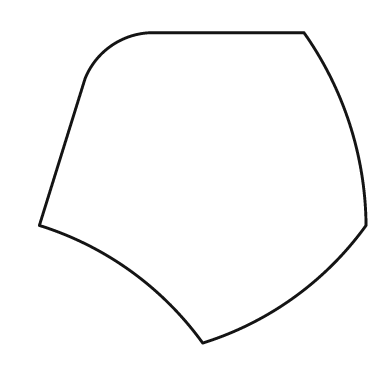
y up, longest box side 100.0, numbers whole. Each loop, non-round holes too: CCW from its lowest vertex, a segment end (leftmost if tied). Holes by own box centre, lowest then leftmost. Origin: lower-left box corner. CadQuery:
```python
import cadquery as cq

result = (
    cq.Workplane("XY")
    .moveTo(50.0, 0.0)
    .threePointArc((78.0, 14.0), (100.0, 36.0))
    .threePointArc((95.0, 67.0), (81.0, 95.0))
    .lineTo(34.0, 95.0)
    .threePointArc((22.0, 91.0), (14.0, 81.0))
    .lineTo(0.0, 36.0)
    .threePointArc((28.0, 22.0), (50.0, 0.0))
    .close()
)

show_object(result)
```